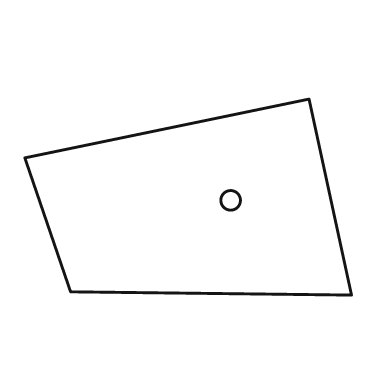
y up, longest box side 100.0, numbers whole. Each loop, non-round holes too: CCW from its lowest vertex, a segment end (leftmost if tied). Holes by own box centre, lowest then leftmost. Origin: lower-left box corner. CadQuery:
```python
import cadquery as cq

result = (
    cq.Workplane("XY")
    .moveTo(100.0, 0.0)
    .lineTo(87.0, 60.0)
    .lineTo(0.0, 42.0)
    .lineTo(14.0, 1.0)
    .close()
    .moveTo(63.0, 29.0)
    .circle(3.0)
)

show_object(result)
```